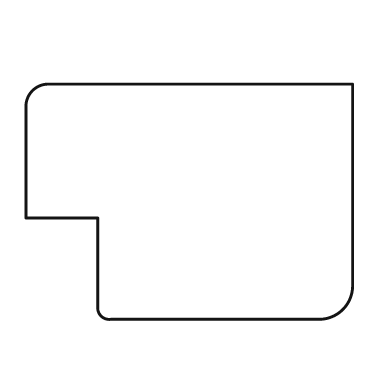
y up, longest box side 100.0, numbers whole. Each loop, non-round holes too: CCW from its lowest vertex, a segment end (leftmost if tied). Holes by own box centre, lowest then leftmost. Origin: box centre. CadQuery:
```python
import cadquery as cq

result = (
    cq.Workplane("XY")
    .moveTo(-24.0, -36.0)
    .lineTo(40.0, -36.0)
    .threePointArc((47.0, -33.0), (50.0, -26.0))
    .lineTo(50.0, 36.0)
    .lineTo(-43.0, 36.0)
    .threePointArc((-48.0, 34.0), (-50.0, 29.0))
    .lineTo(-50.0, -5.0)
    .lineTo(-28.0, -5.0)
    .lineTo(-28.0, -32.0)
    .threePointArc((-27.0, -35.0), (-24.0, -36.0))
    .close()
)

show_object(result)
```